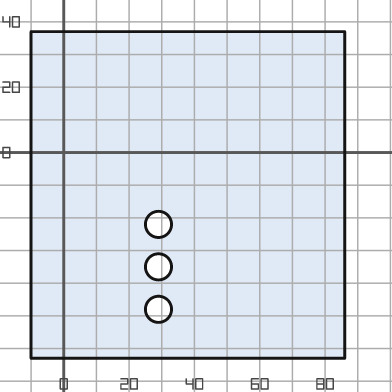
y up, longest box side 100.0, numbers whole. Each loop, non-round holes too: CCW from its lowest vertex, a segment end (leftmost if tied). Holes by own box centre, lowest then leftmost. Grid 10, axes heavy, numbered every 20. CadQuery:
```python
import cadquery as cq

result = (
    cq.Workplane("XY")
    .moveTo(-10.0, -63.0)
    .lineTo(86.0, -63.0)
    .lineTo(86.0, 37.0)
    .lineTo(-10.0, 37.0)
    .close()
    .moveTo(29.0, -48.0)
    .circle(4.0)
    .moveTo(29.0, -35.0)
    .circle(4.0)
    .moveTo(29.0, -22.0)
    .circle(4.0)
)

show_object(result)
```